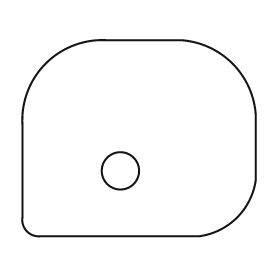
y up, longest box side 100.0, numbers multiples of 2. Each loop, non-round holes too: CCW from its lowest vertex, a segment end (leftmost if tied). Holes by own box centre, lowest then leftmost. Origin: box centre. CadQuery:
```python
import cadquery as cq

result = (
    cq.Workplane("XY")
    .moveTo(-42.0, -42.0)
    .lineTo(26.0, -42.0)
    .threePointArc((42.0, -34.0), (50.0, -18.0))
    .lineTo(50.0, 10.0)
    .threePointArc((40.0, 32.0), (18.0, 42.0))
    .lineTo(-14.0, 42.0)
    .threePointArc((-40.0, 32.0), (-50.0, 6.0))
    .lineTo(-50.0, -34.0)
    .threePointArc((-48.0, -40.0), (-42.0, -42.0))
    .close()
    .moveTo(-8.0, -14.0)
    .circle(8.0)
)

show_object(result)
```